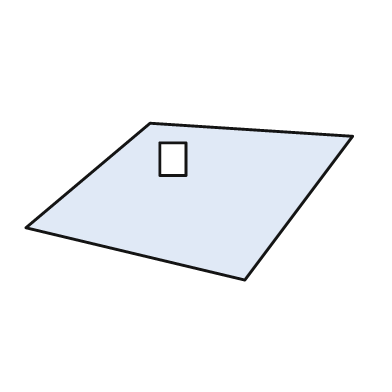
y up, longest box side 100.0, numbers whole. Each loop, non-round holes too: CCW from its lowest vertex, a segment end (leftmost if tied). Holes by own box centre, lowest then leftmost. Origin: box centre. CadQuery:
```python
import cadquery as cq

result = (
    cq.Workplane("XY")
    .moveTo(17.0, -24.0)
    .lineTo(50.0, 20.0)
    .lineTo(-12.0, 24.0)
    .lineTo(-50.0, -8.0)
    .close()
    .moveTo(-9.0, 8.0)
    .lineTo(-1.0, 8.0)
    .lineTo(-1.0, 18.0)
    .lineTo(-9.0, 18.0)
    .close()
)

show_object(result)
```